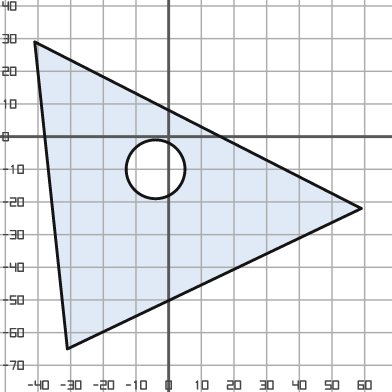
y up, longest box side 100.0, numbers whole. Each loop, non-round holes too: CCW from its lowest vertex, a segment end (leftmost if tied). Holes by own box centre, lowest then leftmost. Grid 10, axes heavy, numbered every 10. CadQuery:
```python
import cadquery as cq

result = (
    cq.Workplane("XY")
    .moveTo(-31.0, -65.0)
    .lineTo(59.0, -22.0)
    .lineTo(-41.0, 29.0)
    .close()
    .moveTo(-4.0, -10.0)
    .circle(9.0)
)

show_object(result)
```